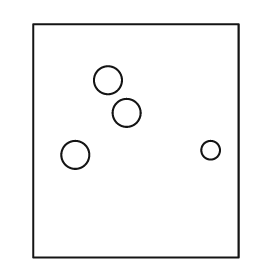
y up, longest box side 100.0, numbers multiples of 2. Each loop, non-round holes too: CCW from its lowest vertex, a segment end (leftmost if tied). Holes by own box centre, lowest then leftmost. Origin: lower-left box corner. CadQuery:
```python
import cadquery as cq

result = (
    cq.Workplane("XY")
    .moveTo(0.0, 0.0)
    .lineTo(88.0, 0.0)
    .lineTo(88.0, 100.0)
    .lineTo(0.0, 100.0)
    .close()
    .moveTo(18.0, 44.0)
    .circle(6.0)
    .moveTo(76.0, 46.0)
    .circle(4.0)
    .moveTo(40.0, 62.0)
    .circle(6.0)
    .moveTo(32.0, 76.0)
    .circle(6.0)
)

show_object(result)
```